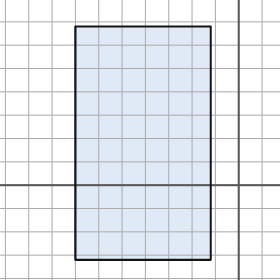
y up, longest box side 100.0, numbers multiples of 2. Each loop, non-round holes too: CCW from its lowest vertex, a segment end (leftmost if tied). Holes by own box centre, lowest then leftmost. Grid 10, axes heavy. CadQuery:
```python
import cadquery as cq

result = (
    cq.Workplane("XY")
    .moveTo(-70.0, -32.0)
    .lineTo(-12.0, -32.0)
    .lineTo(-12.0, 68.0)
    .lineTo(-70.0, 68.0)
    .close()
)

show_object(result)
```